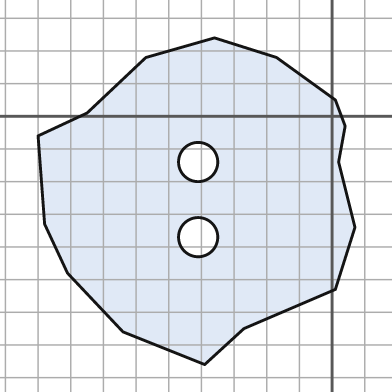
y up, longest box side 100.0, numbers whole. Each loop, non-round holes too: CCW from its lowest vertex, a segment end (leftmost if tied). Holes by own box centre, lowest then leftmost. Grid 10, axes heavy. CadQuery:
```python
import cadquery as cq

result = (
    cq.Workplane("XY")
    .moveTo(-39.0, -76.0)
    .lineTo(-27.0, -65.0)
    .lineTo(1.0, -53.0)
    .lineTo(7.0, -34.0)
    .lineTo(2.0, -14.0)
    .lineTo(4.0, -3.0)
    .lineTo(1.0, 5.0)
    .lineTo(-17.0, 18.0)
    .lineTo(-36.0, 24.0)
    .lineTo(-57.0, 18.0)
    .lineTo(-75.0, 1.0)
    .lineTo(-90.0, -6.0)
    .lineTo(-88.0, -33.0)
    .lineTo(-81.0, -48.0)
    .lineTo(-64.0, -66.0)
    .close()
    .moveTo(-41.0, -37.0)
    .circle(6.0)
    .moveTo(-41.0, -14.0)
    .circle(6.0)
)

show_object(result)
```